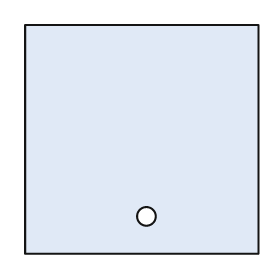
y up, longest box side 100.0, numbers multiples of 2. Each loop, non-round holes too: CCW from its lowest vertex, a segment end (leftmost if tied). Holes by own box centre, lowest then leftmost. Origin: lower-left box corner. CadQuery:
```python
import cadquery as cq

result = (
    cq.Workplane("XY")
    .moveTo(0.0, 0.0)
    .lineTo(100.0, 0.0)
    .lineTo(100.0, 98.0)
    .lineTo(0.0, 98.0)
    .close()
    .moveTo(52.0, 16.0)
    .circle(4.0)
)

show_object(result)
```